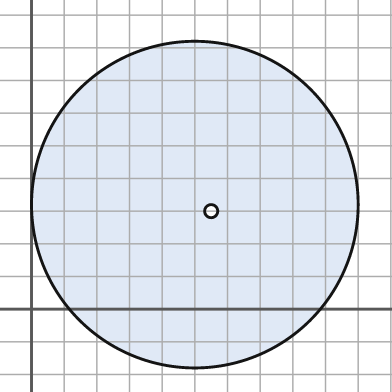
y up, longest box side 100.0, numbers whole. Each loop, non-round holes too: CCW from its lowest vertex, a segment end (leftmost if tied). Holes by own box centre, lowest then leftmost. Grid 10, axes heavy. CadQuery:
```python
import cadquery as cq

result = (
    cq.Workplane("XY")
    .moveTo(50.0, 32.0)
    .circle(50.0)
    .moveTo(55.0, 30.0)
    .circle(2.0)
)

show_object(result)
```